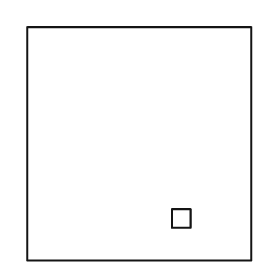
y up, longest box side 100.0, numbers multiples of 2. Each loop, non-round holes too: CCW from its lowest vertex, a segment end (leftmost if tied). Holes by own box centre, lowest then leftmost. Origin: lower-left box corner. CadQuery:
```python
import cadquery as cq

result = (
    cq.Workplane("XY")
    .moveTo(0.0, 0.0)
    .lineTo(96.0, 0.0)
    .lineTo(96.0, 100.0)
    .lineTo(0.0, 100.0)
    .close()
    .moveTo(62.0, 14.0)
    .lineTo(70.0, 14.0)
    .lineTo(70.0, 22.0)
    .lineTo(62.0, 22.0)
    .close()
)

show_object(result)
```